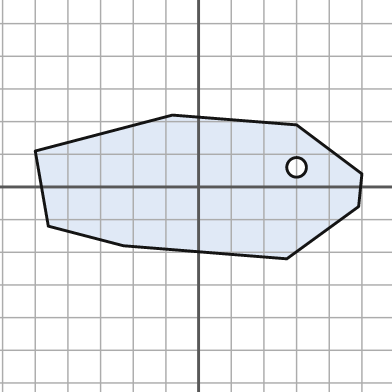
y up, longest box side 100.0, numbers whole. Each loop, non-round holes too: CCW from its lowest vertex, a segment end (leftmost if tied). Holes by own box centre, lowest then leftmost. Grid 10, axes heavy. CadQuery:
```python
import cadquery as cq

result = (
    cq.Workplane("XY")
    .moveTo(27.0, -22.0)
    .lineTo(49.0, -6.0)
    .lineTo(50.0, 4.0)
    .lineTo(30.0, 19.0)
    .lineTo(-8.0, 22.0)
    .lineTo(-50.0, 11.0)
    .lineTo(-46.0, -12.0)
    .lineTo(-23.0, -18.0)
    .close()
    .moveTo(30.0, 6.0)
    .circle(3.0)
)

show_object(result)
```